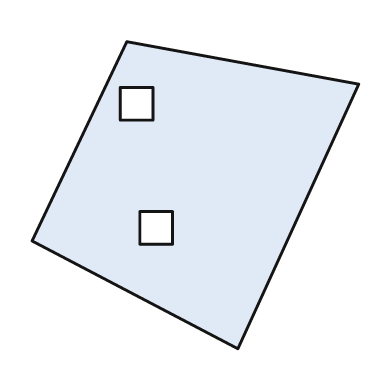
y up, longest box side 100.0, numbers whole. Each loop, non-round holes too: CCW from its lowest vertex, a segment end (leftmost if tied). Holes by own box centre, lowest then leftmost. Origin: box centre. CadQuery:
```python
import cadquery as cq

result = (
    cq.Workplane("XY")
    .moveTo(13.0, -47.0)
    .lineTo(50.0, 34.0)
    .lineTo(-21.0, 47.0)
    .lineTo(-50.0, -14.0)
    .close()
    .moveTo(-17.0, -15.0)
    .lineTo(-7.0, -15.0)
    .lineTo(-7.0, -5.0)
    .lineTo(-17.0, -5.0)
    .close()
    .moveTo(-23.0, 23.0)
    .lineTo(-13.0, 23.0)
    .lineTo(-13.0, 33.0)
    .lineTo(-23.0, 33.0)
    .close()
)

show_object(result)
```